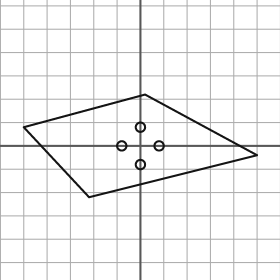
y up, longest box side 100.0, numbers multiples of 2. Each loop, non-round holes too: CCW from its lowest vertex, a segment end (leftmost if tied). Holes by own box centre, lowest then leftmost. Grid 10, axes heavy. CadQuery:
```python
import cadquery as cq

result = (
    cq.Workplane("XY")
    .moveTo(-22.0, -22.0)
    .lineTo(50.0, -4.0)
    .lineTo(2.0, 22.0)
    .lineTo(-50.0, 8.0)
    .close()
    .moveTo(0.0, -8.0)
    .circle(2.0)
    .moveTo(-8.0, 0.0)
    .circle(2.0)
    .moveTo(8.0, 0.0)
    .circle(2.0)
    .moveTo(0.0, 8.0)
    .circle(2.0)
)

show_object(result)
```